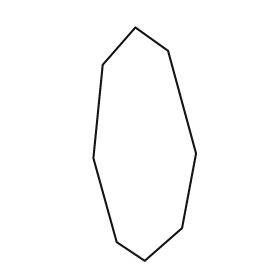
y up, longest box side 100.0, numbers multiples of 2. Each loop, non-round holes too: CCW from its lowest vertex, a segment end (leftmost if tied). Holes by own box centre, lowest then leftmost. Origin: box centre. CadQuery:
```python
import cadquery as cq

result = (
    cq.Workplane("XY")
    .moveTo(0.0, -50.0)
    .lineTo(16.0, -36.0)
    .lineTo(22.0, -4.0)
    .lineTo(10.0, 40.0)
    .lineTo(-4.0, 50.0)
    .lineTo(-18.0, 34.0)
    .lineTo(-22.0, -6.0)
    .lineTo(-12.0, -42.0)
    .close()
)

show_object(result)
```